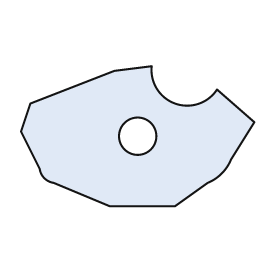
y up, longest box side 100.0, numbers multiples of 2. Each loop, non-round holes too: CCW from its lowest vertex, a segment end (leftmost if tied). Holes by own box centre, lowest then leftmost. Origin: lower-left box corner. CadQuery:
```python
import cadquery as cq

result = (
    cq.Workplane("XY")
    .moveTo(38.0, 0.0)
    .lineTo(66.0, 0.0)
    .lineTo(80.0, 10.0)
    .threePointArc((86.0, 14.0), (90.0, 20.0))
    .lineTo(100.0, 36.0)
    .lineTo(84.0, 50.0)
    .threePointArc((66.0, 44.0), (56.0, 60.0))
    .lineTo(40.0, 58.0)
    .lineTo(4.0, 44.0)
    .lineTo(0.0, 32.0)
    .lineTo(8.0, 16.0)
    .threePointArc((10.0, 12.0), (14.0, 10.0))
    .close()
    .moveTo(50.0, 30.0)
    .circle(8.0)
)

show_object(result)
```